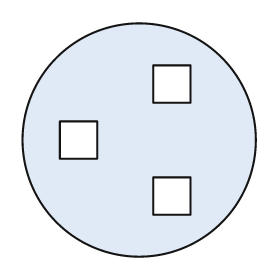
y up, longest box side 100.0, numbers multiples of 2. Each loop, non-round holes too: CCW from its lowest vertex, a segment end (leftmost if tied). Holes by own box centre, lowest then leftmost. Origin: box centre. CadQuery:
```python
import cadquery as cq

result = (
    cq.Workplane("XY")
    .moveTo(0.0, 0.0)
    .circle(50.0)
    .moveTo(6.0, -32.0)
    .lineTo(22.0, -32.0)
    .lineTo(22.0, -16.0)
    .lineTo(6.0, -16.0)
    .close()
    .moveTo(-34.0, -8.0)
    .lineTo(-18.0, -8.0)
    .lineTo(-18.0, 8.0)
    .lineTo(-34.0, 8.0)
    .close()
    .moveTo(6.0, 16.0)
    .lineTo(22.0, 16.0)
    .lineTo(22.0, 32.0)
    .lineTo(6.0, 32.0)
    .close()
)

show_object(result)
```